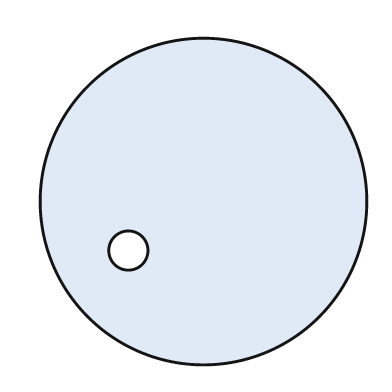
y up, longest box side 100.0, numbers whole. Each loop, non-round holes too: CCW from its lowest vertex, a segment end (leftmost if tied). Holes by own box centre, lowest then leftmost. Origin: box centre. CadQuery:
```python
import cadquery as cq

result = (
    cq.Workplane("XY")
    .moveTo(0.0, 0.0)
    .circle(50.0)
    .moveTo(-23.0, -15.0)
    .circle(6.0)
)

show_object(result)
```